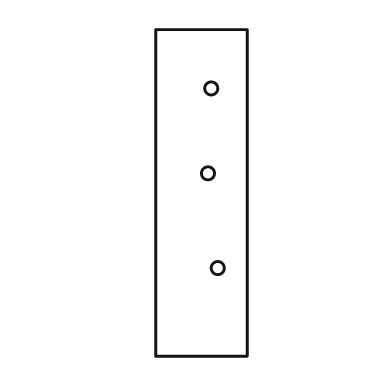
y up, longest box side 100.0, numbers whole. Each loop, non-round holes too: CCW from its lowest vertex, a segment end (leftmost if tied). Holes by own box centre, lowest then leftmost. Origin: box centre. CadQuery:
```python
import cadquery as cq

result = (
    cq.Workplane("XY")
    .moveTo(-14.0, -50.0)
    .lineTo(14.0, -50.0)
    .lineTo(14.0, 50.0)
    .lineTo(-14.0, 50.0)
    .close()
    .moveTo(5.0, -23.0)
    .circle(2.0)
    .moveTo(2.0, 6.0)
    .circle(2.0)
    .moveTo(3.0, 32.0)
    .circle(2.0)
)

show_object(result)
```